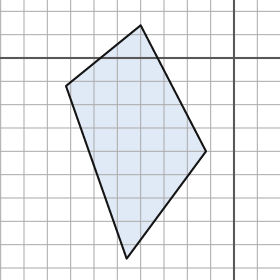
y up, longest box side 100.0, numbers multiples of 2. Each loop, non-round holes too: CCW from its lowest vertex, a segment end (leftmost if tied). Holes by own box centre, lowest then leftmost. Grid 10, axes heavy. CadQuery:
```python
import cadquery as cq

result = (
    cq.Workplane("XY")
    .moveTo(-46.0, -86.0)
    .lineTo(-12.0, -40.0)
    .lineTo(-40.0, 14.0)
    .lineTo(-72.0, -12.0)
    .close()
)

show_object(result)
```